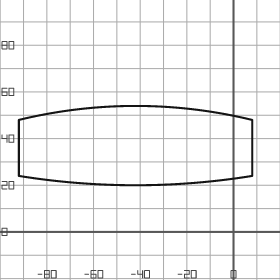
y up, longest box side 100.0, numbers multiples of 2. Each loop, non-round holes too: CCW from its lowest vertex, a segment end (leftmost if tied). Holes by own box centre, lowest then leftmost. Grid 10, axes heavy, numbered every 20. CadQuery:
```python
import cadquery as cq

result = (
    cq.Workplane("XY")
    .moveTo(-92.0, 24.0)
    .threePointArc((-42.0, 20.0), (8.0, 24.0))
    .lineTo(8.0, 48.0)
    .threePointArc((-42.0, 54.0), (-92.0, 48.0))
    .close()
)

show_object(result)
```